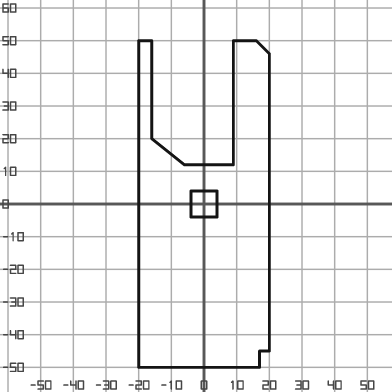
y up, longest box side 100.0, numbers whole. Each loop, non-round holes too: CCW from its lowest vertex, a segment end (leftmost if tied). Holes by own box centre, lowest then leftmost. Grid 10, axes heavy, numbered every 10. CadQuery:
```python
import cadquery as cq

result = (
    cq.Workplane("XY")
    .moveTo(-20.0, -50.0)
    .lineTo(17.0, -50.0)
    .lineTo(17.0, -45.0)
    .lineTo(20.0, -45.0)
    .lineTo(20.0, 46.0)
    .lineTo(16.0, 50.0)
    .lineTo(9.0, 50.0)
    .lineTo(9.0, 12.0)
    .lineTo(-6.0, 12.0)
    .lineTo(-16.0, 20.0)
    .lineTo(-16.0, 50.0)
    .lineTo(-20.0, 50.0)
    .close()
    .moveTo(-4.0, -4.0)
    .lineTo(4.0, -4.0)
    .lineTo(4.0, 4.0)
    .lineTo(-4.0, 4.0)
    .close()
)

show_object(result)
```